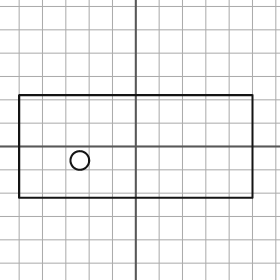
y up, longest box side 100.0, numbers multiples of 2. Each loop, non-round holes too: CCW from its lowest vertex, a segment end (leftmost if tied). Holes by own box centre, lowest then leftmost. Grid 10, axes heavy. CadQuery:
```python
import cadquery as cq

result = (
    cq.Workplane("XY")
    .moveTo(-50.0, -22.0)
    .lineTo(50.0, -22.0)
    .lineTo(50.0, 22.0)
    .lineTo(-50.0, 22.0)
    .close()
    .moveTo(-24.0, -6.0)
    .circle(4.0)
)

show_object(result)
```